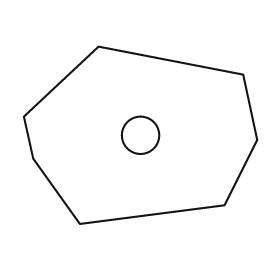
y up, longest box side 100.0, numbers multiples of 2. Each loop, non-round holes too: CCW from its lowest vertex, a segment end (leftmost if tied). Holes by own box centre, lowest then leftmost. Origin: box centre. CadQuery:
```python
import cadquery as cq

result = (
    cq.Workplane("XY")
    .moveTo(-26.0, -38.0)
    .lineTo(36.0, -30.0)
    .lineTo(50.0, -2.0)
    .lineTo(44.0, 26.0)
    .lineTo(-18.0, 38.0)
    .lineTo(-50.0, 8.0)
    .lineTo(-46.0, -10.0)
    .close()
    .moveTo(0.0, 0.0)
    .circle(8.0)
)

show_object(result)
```